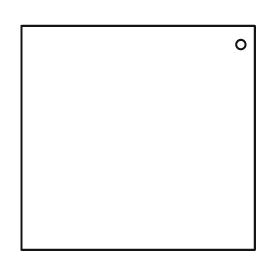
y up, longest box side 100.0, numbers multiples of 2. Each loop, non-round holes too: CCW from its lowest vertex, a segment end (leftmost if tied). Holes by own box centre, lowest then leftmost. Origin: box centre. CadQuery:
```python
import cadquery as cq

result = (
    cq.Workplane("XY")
    .moveTo(-50.0, -48.0)
    .lineTo(50.0, -48.0)
    .lineTo(50.0, 48.0)
    .lineTo(-50.0, 48.0)
    .close()
    .moveTo(44.0, 40.0)
    .circle(2.0)
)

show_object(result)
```